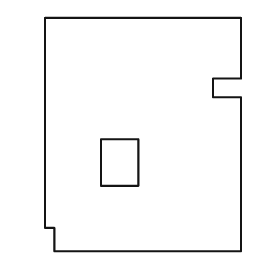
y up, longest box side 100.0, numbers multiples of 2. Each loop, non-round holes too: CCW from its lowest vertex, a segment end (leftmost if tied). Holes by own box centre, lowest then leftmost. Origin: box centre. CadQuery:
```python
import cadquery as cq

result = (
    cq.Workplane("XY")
    .moveTo(-38.0, -50.0)
    .lineTo(42.0, -50.0)
    .lineTo(42.0, 16.0)
    .lineTo(30.0, 16.0)
    .lineTo(30.0, 24.0)
    .lineTo(42.0, 24.0)
    .lineTo(42.0, 50.0)
    .lineTo(-42.0, 50.0)
    .lineTo(-42.0, -40.0)
    .lineTo(-38.0, -40.0)
    .close()
    .moveTo(-18.0, -22.0)
    .lineTo(-2.0, -22.0)
    .lineTo(-2.0, -2.0)
    .lineTo(-18.0, -2.0)
    .close()
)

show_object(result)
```